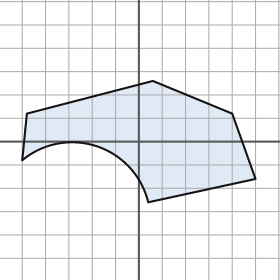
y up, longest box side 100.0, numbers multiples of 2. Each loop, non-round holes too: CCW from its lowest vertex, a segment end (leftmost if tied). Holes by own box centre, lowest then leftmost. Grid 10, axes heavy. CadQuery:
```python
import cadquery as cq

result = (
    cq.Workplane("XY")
    .moveTo(4.0, -26.0)
    .lineTo(50.0, -16.0)
    .lineTo(40.0, 12.0)
    .lineTo(6.0, 26.0)
    .lineTo(-48.0, 12.0)
    .lineTo(-50.0, -8.0)
    .threePointArc((-18.0, -2.0), (4.0, -26.0))
    .close()
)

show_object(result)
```